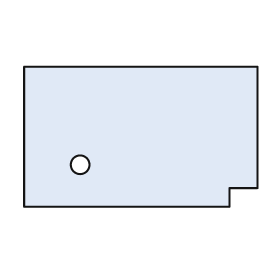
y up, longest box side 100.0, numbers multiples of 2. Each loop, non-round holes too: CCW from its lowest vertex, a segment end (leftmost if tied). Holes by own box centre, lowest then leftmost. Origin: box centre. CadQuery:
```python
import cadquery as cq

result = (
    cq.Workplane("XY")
    .moveTo(-50.0, -30.0)
    .lineTo(38.0, -30.0)
    .lineTo(38.0, -22.0)
    .lineTo(50.0, -22.0)
    .lineTo(50.0, 30.0)
    .lineTo(-50.0, 30.0)
    .close()
    .moveTo(-26.0, -12.0)
    .circle(4.0)
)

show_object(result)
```